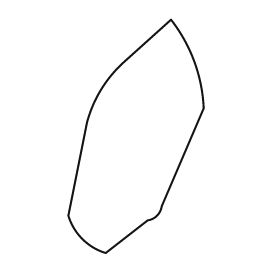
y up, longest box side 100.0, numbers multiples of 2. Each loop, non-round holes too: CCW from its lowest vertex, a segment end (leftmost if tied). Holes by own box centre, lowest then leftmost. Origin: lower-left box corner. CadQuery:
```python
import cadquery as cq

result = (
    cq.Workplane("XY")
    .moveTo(16.0, 0.0)
    .lineTo(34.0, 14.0)
    .threePointArc((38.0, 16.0), (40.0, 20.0))
    .lineTo(58.0, 62.0)
    .threePointArc((54.0, 82.0), (44.0, 100.0))
    .lineTo(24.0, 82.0)
    .threePointArc((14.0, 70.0), (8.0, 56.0))
    .lineTo(0.0, 16.0)
    .threePointArc((6.0, 6.0), (16.0, 0.0))
    .close()
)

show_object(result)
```